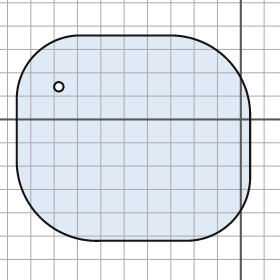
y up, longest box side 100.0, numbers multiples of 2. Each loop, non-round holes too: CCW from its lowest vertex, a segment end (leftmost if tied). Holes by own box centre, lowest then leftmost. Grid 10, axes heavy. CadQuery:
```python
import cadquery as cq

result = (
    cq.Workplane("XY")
    .moveTo(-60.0, -52.0)
    .lineTo(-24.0, -52.0)
    .threePointArc((-4.0, -44.0), (4.0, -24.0))
    .lineTo(4.0, 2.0)
    .threePointArc((-6.0, 26.0), (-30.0, 36.0))
    .lineTo(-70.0, 36.0)
    .threePointArc((-88.0, 28.0), (-96.0, 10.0))
    .lineTo(-96.0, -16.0)
    .threePointArc((-86.0, -42.0), (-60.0, -52.0))
    .close()
    .moveTo(-78.0, 14.0)
    .circle(2.0)
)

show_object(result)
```